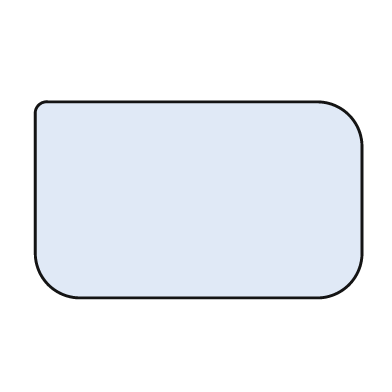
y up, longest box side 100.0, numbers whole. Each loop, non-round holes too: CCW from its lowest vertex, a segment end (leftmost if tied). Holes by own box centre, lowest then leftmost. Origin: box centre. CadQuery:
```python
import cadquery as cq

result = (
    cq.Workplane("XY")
    .moveTo(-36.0, -30.0)
    .lineTo(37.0, -30.0)
    .threePointArc((46.0, -26.0), (50.0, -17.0))
    .lineTo(50.0, 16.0)
    .threePointArc((46.0, 26.0), (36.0, 30.0))
    .lineTo(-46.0, 30.0)
    .threePointArc((-49.0, 29.0), (-50.0, 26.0))
    .lineTo(-50.0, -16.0)
    .threePointArc((-46.0, -26.0), (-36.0, -30.0))
    .close()
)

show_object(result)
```